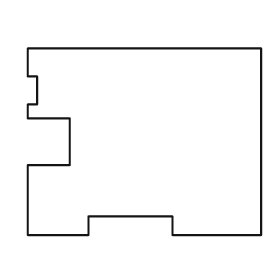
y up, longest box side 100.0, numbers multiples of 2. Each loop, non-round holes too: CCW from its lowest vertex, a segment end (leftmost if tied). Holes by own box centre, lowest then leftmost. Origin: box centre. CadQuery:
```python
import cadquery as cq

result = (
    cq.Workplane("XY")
    .moveTo(-50.0, -40.0)
    .lineTo(-24.0, -40.0)
    .lineTo(-24.0, -32.0)
    .lineTo(12.0, -32.0)
    .lineTo(12.0, -40.0)
    .lineTo(50.0, -40.0)
    .lineTo(50.0, 40.0)
    .lineTo(-50.0, 40.0)
    .lineTo(-50.0, 28.0)
    .lineTo(-46.0, 28.0)
    .lineTo(-46.0, 16.0)
    .lineTo(-50.0, 16.0)
    .lineTo(-50.0, 10.0)
    .lineTo(-32.0, 10.0)
    .lineTo(-32.0, -10.0)
    .lineTo(-50.0, -10.0)
    .close()
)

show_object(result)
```